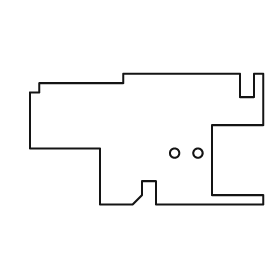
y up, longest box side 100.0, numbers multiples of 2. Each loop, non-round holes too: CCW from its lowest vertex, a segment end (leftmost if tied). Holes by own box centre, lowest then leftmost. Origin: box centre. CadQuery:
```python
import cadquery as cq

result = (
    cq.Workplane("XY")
    .moveTo(-20.0, -28.0)
    .lineTo(-6.0, -28.0)
    .lineTo(-2.0, -24.0)
    .lineTo(-2.0, -18.0)
    .lineTo(4.0, -18.0)
    .lineTo(4.0, -28.0)
    .lineTo(50.0, -28.0)
    .lineTo(50.0, -24.0)
    .lineTo(28.0, -24.0)
    .lineTo(28.0, 6.0)
    .lineTo(50.0, 6.0)
    .lineTo(50.0, 28.0)
    .lineTo(46.0, 28.0)
    .lineTo(46.0, 18.0)
    .lineTo(40.0, 18.0)
    .lineTo(40.0, 28.0)
    .lineTo(-10.0, 28.0)
    .lineTo(-10.0, 24.0)
    .lineTo(-46.0, 24.0)
    .lineTo(-46.0, 20.0)
    .lineTo(-50.0, 20.0)
    .lineTo(-50.0, -4.0)
    .lineTo(-20.0, -4.0)
    .close()
    .moveTo(12.0, -6.0)
    .circle(2.0)
    .moveTo(22.0, -6.0)
    .circle(2.0)
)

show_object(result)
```